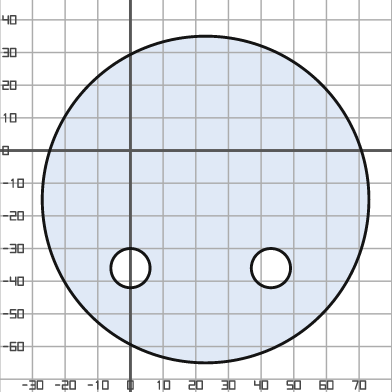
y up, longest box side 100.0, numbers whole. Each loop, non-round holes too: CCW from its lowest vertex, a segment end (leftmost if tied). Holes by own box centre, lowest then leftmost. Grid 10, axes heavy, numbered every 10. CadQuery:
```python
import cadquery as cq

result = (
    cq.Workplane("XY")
    .moveTo(23.0, -15.0)
    .circle(50.0)
    .moveTo(0.0, -36.0)
    .circle(6.0)
    .moveTo(43.0, -36.0)
    .circle(6.0)
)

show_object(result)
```